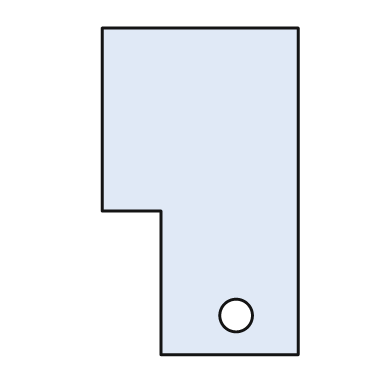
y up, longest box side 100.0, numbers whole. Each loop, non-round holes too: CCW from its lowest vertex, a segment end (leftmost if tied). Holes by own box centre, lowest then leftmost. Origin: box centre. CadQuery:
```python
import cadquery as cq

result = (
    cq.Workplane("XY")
    .moveTo(-12.0, -50.0)
    .lineTo(30.0, -50.0)
    .lineTo(30.0, 50.0)
    .lineTo(-30.0, 50.0)
    .lineTo(-30.0, -6.0)
    .lineTo(-12.0, -6.0)
    .close()
    .moveTo(11.0, -38.0)
    .circle(5.0)
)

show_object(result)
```